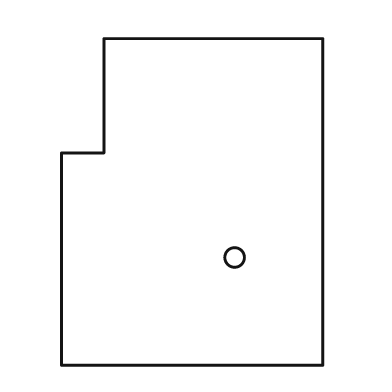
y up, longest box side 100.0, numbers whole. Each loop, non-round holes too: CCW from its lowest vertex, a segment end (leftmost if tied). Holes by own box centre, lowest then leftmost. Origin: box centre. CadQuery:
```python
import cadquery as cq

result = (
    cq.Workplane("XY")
    .moveTo(-40.0, -50.0)
    .lineTo(40.0, -50.0)
    .lineTo(40.0, 50.0)
    .lineTo(-27.0, 50.0)
    .lineTo(-27.0, 15.0)
    .lineTo(-40.0, 15.0)
    .close()
    .moveTo(13.0, -17.0)
    .circle(3.0)
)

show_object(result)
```